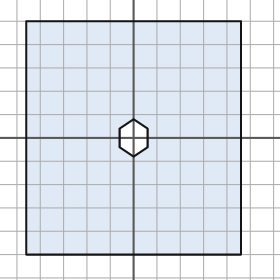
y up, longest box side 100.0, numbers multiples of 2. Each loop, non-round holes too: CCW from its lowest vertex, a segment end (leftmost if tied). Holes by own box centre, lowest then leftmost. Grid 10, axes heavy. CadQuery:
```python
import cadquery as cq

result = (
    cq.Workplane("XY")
    .moveTo(-46.0, -50.0)
    .lineTo(46.0, -50.0)
    .lineTo(46.0, 50.0)
    .lineTo(-46.0, 50.0)
    .close()
    .moveTo(0.0, -8.0)
    .lineTo(6.0, -4.0)
    .lineTo(6.0, 4.0)
    .lineTo(0.0, 8.0)
    .lineTo(-6.0, 4.0)
    .lineTo(-6.0, -4.0)
    .close()
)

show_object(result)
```